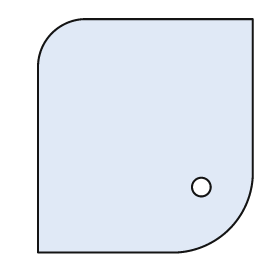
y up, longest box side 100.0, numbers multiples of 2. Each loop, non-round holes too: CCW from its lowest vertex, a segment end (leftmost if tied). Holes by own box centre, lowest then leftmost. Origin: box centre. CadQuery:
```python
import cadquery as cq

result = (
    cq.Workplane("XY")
    .moveTo(-46.0, -50.0)
    .lineTo(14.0, -50.0)
    .threePointArc((36.0, -40.0), (46.0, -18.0))
    .lineTo(46.0, 50.0)
    .lineTo(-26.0, 50.0)
    .threePointArc((-40.0, 44.0), (-46.0, 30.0))
    .close()
    .moveTo(24.0, -22.0)
    .circle(4.0)
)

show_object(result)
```